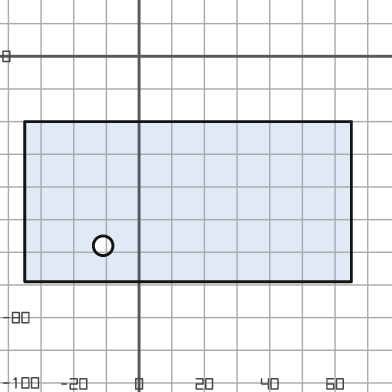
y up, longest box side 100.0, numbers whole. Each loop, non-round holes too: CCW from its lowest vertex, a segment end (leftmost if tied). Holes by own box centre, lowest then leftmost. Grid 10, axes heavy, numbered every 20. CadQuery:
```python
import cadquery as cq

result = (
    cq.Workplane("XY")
    .moveTo(-35.0, -69.0)
    .lineTo(65.0, -69.0)
    .lineTo(65.0, -20.0)
    .lineTo(-35.0, -20.0)
    .close()
    .moveTo(-11.0, -58.0)
    .circle(3.0)
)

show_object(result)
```